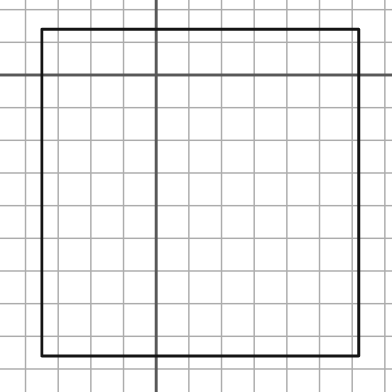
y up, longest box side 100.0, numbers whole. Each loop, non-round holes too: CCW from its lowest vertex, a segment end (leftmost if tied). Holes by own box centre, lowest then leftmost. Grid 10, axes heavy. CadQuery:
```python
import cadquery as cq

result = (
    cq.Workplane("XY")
    .moveTo(-35.0, -86.0)
    .lineTo(62.0, -86.0)
    .lineTo(62.0, 14.0)
    .lineTo(-35.0, 14.0)
    .close()
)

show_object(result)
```